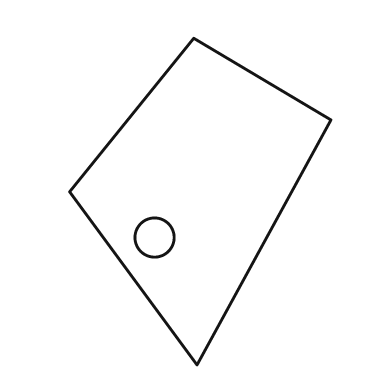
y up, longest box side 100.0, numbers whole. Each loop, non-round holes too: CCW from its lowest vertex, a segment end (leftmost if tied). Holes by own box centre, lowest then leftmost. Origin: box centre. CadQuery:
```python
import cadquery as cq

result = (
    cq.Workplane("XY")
    .moveTo(-1.0, -50.0)
    .lineTo(40.0, 25.0)
    .lineTo(-2.0, 50.0)
    .lineTo(-40.0, 3.0)
    .close()
    .moveTo(-14.0, -11.0)
    .circle(6.0)
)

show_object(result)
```